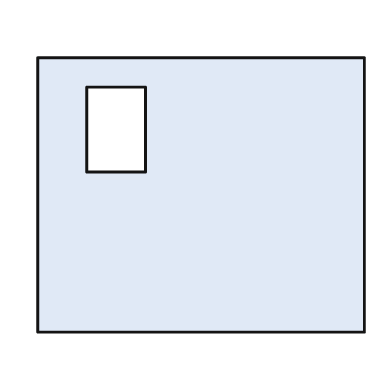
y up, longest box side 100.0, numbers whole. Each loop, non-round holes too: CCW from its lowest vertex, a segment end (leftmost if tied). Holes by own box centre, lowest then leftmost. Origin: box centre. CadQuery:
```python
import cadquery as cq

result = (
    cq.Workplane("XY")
    .moveTo(-50.0, -42.0)
    .lineTo(50.0, -42.0)
    .lineTo(50.0, 42.0)
    .lineTo(-50.0, 42.0)
    .close()
    .moveTo(-35.0, 7.0)
    .lineTo(-17.0, 7.0)
    .lineTo(-17.0, 33.0)
    .lineTo(-35.0, 33.0)
    .close()
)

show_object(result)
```